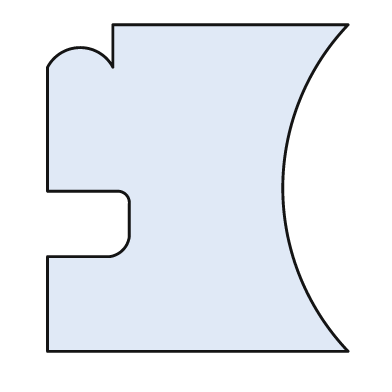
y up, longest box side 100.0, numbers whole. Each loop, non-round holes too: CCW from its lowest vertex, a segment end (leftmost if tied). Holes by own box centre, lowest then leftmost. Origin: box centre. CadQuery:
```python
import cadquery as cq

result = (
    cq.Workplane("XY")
    .moveTo(-46.0, -50.0)
    .lineTo(46.0, -50.0)
    .threePointArc((26.0, 0.0), (46.0, 50.0))
    .lineTo(-26.0, 50.0)
    .lineTo(-26.0, 37.0)
    .threePointArc((-36.0, 43.0), (-46.0, 37.0))
    .lineTo(-46.0, -1.0)
    .lineTo(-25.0, -1.0)
    .threePointArc((-22.0, -2.0), (-21.0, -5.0))
    .lineTo(-21.0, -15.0)
    .threePointArc((-23.0, -19.0), (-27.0, -21.0))
    .lineTo(-46.0, -21.0)
    .close()
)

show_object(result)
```